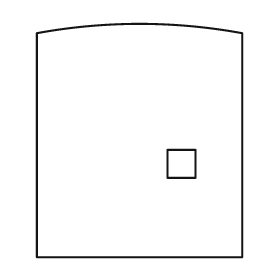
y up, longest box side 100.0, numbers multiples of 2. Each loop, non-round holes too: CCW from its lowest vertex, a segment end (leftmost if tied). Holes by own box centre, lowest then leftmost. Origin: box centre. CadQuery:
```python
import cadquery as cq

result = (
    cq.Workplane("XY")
    .moveTo(-44.0, -50.0)
    .lineTo(44.0, -50.0)
    .lineTo(44.0, 46.0)
    .threePointArc((0.0, 50.0), (-44.0, 46.0))
    .close()
    .moveTo(12.0, -16.0)
    .lineTo(24.0, -16.0)
    .lineTo(24.0, -4.0)
    .lineTo(12.0, -4.0)
    .close()
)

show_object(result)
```